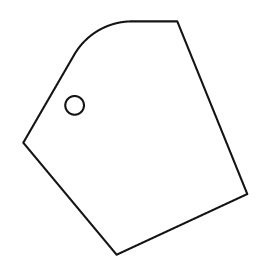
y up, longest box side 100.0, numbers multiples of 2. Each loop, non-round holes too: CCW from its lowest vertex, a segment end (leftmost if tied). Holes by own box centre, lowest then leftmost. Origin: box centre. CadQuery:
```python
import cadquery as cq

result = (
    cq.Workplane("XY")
    .moveTo(-8.0, -50.0)
    .lineTo(48.0, -24.0)
    .lineTo(18.0, 50.0)
    .lineTo(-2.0, 50.0)
    .threePointArc((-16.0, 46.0), (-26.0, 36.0))
    .lineTo(-48.0, -2.0)
    .close()
    .moveTo(-26.0, 14.0)
    .circle(4.0)
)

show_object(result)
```